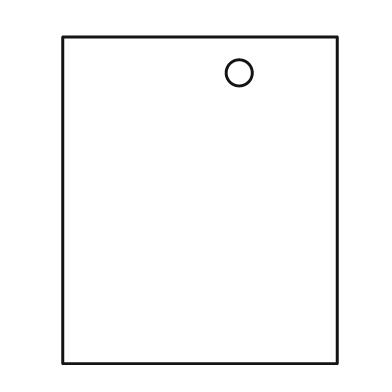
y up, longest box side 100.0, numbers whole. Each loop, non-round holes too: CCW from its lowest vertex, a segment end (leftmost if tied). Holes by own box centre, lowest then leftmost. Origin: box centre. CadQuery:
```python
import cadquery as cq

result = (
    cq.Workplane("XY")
    .moveTo(-42.0, -50.0)
    .lineTo(42.0, -50.0)
    .lineTo(42.0, 50.0)
    .lineTo(-42.0, 50.0)
    .close()
    .moveTo(12.0, 39.0)
    .circle(4.0)
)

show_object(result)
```